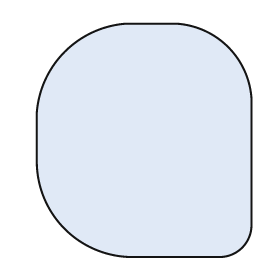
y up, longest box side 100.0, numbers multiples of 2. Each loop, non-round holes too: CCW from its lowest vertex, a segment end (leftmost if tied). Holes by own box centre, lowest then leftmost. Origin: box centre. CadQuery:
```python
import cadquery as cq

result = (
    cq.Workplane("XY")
    .moveTo(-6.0, -50.0)
    .lineTo(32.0, -50.0)
    .threePointArc((42.0, -46.0), (46.0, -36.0))
    .lineTo(46.0, 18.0)
    .threePointArc((36.0, 40.0), (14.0, 50.0))
    .lineTo(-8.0, 50.0)
    .threePointArc((-34.0, 38.0), (-46.0, 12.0))
    .lineTo(-46.0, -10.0)
    .threePointArc((-34.0, -38.0), (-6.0, -50.0))
    .close()
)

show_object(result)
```